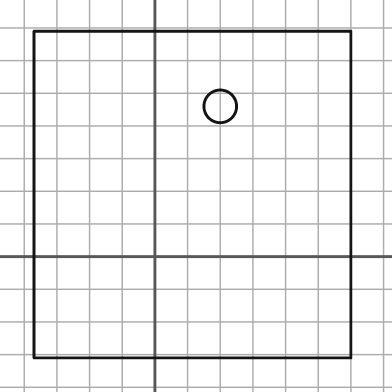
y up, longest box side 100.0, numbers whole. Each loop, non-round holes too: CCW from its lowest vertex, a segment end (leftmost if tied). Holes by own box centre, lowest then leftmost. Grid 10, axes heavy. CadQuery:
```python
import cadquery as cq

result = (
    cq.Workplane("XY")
    .moveTo(-37.0, -31.0)
    .lineTo(60.0, -31.0)
    .lineTo(60.0, 69.0)
    .lineTo(-37.0, 69.0)
    .close()
    .moveTo(20.0, 46.0)
    .circle(5.0)
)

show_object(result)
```